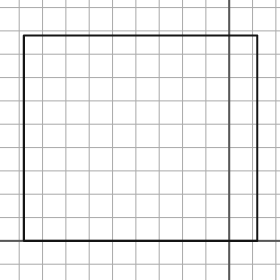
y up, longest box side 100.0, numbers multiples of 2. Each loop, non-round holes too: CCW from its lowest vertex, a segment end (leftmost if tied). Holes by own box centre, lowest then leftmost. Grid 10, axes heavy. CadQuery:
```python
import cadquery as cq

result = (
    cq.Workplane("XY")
    .moveTo(-88.0, 0.0)
    .lineTo(12.0, 0.0)
    .lineTo(12.0, 88.0)
    .lineTo(-88.0, 88.0)
    .close()
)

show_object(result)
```